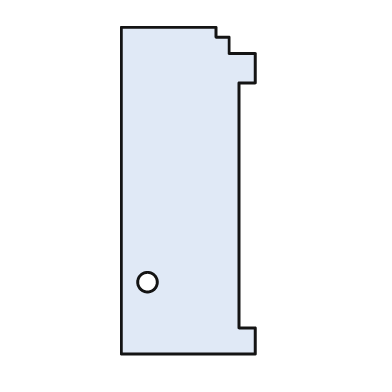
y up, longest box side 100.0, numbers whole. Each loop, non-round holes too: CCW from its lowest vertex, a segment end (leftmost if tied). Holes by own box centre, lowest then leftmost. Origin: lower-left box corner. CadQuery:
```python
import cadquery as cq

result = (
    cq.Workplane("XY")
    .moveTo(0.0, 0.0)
    .lineTo(41.0, 0.0)
    .lineTo(41.0, 8.0)
    .lineTo(36.0, 8.0)
    .lineTo(36.0, 83.0)
    .lineTo(41.0, 83.0)
    .lineTo(41.0, 92.0)
    .lineTo(33.0, 92.0)
    .lineTo(33.0, 97.0)
    .lineTo(29.0, 97.0)
    .lineTo(29.0, 100.0)
    .lineTo(0.0, 100.0)
    .close()
    .moveTo(8.0, 22.0)
    .circle(3.0)
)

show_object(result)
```